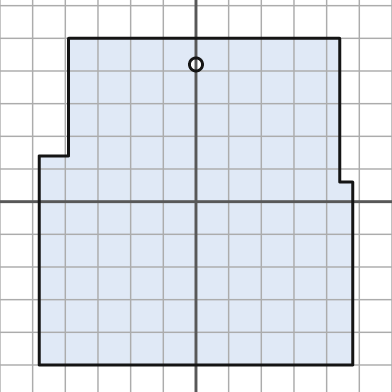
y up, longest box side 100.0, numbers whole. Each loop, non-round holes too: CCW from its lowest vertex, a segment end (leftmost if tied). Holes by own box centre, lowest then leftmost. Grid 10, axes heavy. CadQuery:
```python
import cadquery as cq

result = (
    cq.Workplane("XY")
    .moveTo(-48.0, -50.0)
    .lineTo(48.0, -50.0)
    .lineTo(48.0, 6.0)
    .lineTo(44.0, 6.0)
    .lineTo(44.0, 50.0)
    .lineTo(-39.0, 50.0)
    .lineTo(-39.0, 14.0)
    .lineTo(-48.0, 14.0)
    .close()
    .moveTo(0.0, 42.0)
    .circle(2.0)
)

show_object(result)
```